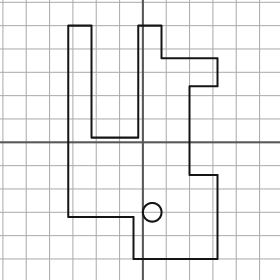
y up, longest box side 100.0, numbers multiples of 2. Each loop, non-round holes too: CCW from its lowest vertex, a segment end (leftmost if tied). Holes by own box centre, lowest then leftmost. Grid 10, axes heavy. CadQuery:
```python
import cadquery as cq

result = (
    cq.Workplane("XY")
    .moveTo(-4.0, -50.0)
    .lineTo(32.0, -50.0)
    .lineTo(32.0, -14.0)
    .lineTo(20.0, -14.0)
    .lineTo(20.0, 24.0)
    .lineTo(32.0, 24.0)
    .lineTo(32.0, 36.0)
    .lineTo(8.0, 36.0)
    .lineTo(8.0, 50.0)
    .lineTo(-2.0, 50.0)
    .lineTo(-2.0, 2.0)
    .lineTo(-22.0, 2.0)
    .lineTo(-22.0, 50.0)
    .lineTo(-32.0, 50.0)
    .lineTo(-32.0, -32.0)
    .lineTo(-4.0, -32.0)
    .close()
    .moveTo(4.0, -30.0)
    .circle(4.0)
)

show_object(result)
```